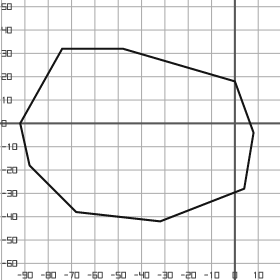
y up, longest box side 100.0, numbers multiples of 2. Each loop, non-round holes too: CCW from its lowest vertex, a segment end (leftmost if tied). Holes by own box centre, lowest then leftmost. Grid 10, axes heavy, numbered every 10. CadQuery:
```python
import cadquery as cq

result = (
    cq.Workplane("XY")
    .moveTo(-32.0, -42.0)
    .lineTo(4.0, -28.0)
    .lineTo(8.0, -4.0)
    .lineTo(0.0, 18.0)
    .lineTo(-48.0, 32.0)
    .lineTo(-74.0, 32.0)
    .lineTo(-92.0, 0.0)
    .lineTo(-88.0, -18.0)
    .lineTo(-68.0, -38.0)
    .close()
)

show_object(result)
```